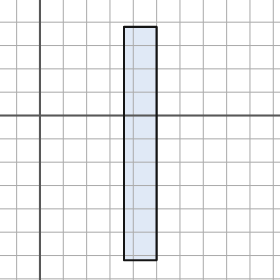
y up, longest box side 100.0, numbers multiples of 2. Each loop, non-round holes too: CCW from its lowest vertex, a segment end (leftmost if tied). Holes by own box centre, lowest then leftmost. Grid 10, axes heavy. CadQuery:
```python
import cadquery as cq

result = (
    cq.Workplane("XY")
    .moveTo(36.0, -62.0)
    .lineTo(50.0, -62.0)
    .lineTo(50.0, 38.0)
    .lineTo(36.0, 38.0)
    .close()
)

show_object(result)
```